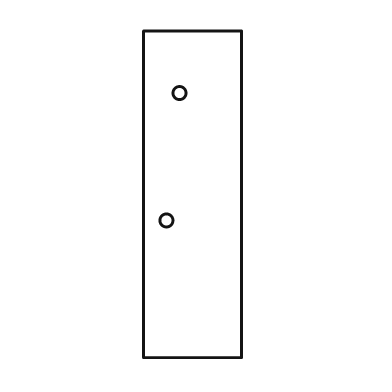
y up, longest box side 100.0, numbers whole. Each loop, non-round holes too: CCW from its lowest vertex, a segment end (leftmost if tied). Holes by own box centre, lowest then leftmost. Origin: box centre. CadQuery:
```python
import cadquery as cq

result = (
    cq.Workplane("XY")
    .moveTo(-15.0, -50.0)
    .lineTo(15.0, -50.0)
    .lineTo(15.0, 50.0)
    .lineTo(-15.0, 50.0)
    .close()
    .moveTo(-8.0, -8.0)
    .circle(2.0)
    .moveTo(-4.0, 31.0)
    .circle(2.0)
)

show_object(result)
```